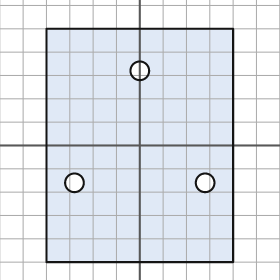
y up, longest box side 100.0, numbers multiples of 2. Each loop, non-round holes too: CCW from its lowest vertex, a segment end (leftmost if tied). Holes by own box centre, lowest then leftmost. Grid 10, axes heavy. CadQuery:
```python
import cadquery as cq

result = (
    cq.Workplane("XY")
    .moveTo(-40.0, -50.0)
    .lineTo(40.0, -50.0)
    .lineTo(40.0, 50.0)
    .lineTo(-40.0, 50.0)
    .close()
    .moveTo(-28.0, -16.0)
    .circle(4.0)
    .moveTo(28.0, -16.0)
    .circle(4.0)
    .moveTo(0.0, 32.0)
    .circle(4.0)
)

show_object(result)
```